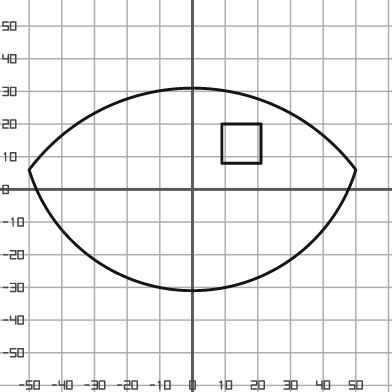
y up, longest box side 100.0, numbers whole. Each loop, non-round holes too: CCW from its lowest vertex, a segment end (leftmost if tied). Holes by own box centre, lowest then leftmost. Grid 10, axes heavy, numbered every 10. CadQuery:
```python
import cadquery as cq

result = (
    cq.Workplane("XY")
    .moveTo(-50.0, 6.0)
    .threePointArc((0.0, -31.0), (50.0, 6.0))
    .threePointArc((0.0, 31.0), (-50.0, 6.0))
    .close()
    .moveTo(9.0, 8.0)
    .lineTo(21.0, 8.0)
    .lineTo(21.0, 20.0)
    .lineTo(9.0, 20.0)
    .close()
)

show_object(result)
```